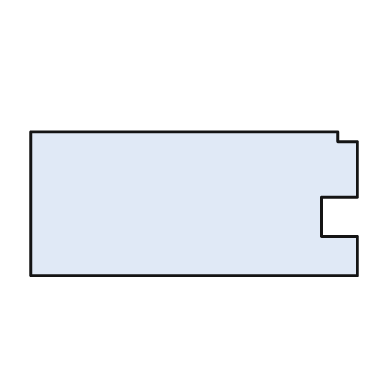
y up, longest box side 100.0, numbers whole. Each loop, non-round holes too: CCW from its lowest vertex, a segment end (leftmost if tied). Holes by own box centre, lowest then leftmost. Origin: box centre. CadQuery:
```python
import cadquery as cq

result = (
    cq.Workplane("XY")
    .moveTo(-50.0, -22.0)
    .lineTo(50.0, -22.0)
    .lineTo(50.0, -10.0)
    .lineTo(39.0, -10.0)
    .lineTo(39.0, 2.0)
    .lineTo(50.0, 2.0)
    .lineTo(50.0, 19.0)
    .lineTo(44.0, 19.0)
    .lineTo(44.0, 22.0)
    .lineTo(-50.0, 22.0)
    .close()
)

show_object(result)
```